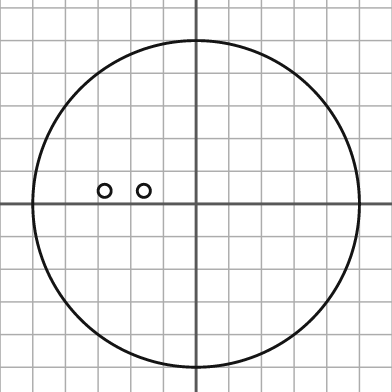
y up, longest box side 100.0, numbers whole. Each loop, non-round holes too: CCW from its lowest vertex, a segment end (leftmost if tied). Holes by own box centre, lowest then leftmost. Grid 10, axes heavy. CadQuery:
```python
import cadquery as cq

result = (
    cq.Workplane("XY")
    .moveTo(0.0, 0.0)
    .circle(50.0)
    .moveTo(-28.0, 4.0)
    .circle(2.0)
    .moveTo(-16.0, 4.0)
    .circle(2.0)
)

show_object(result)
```